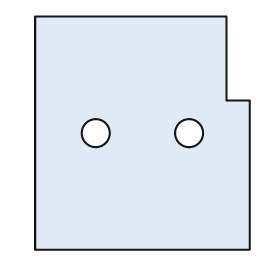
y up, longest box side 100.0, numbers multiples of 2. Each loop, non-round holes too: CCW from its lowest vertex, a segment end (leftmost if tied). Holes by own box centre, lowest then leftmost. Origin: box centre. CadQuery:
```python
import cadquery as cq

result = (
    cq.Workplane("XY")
    .moveTo(-46.0, -50.0)
    .lineTo(46.0, -50.0)
    .lineTo(46.0, 14.0)
    .lineTo(36.0, 14.0)
    .lineTo(36.0, 50.0)
    .lineTo(-46.0, 50.0)
    .close()
    .moveTo(-20.0, 0.0)
    .circle(6.0)
    .moveTo(20.0, 0.0)
    .circle(6.0)
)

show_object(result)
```